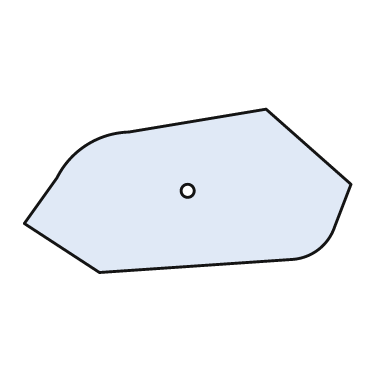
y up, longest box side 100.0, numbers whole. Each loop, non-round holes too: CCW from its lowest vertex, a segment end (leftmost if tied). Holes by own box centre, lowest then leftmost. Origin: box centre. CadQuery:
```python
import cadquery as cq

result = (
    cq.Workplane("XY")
    .moveTo(-27.0, -25.0)
    .lineTo(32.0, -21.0)
    .threePointArc((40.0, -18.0), (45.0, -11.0))
    .lineTo(50.0, 2.0)
    .lineTo(24.0, 25.0)
    .lineTo(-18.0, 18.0)
    .threePointArc((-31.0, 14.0), (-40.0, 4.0))
    .lineTo(-50.0, -10.0)
    .close()
    .moveTo(0.0, 0.0)
    .circle(2.0)
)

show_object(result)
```